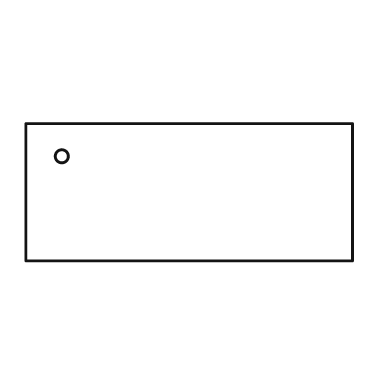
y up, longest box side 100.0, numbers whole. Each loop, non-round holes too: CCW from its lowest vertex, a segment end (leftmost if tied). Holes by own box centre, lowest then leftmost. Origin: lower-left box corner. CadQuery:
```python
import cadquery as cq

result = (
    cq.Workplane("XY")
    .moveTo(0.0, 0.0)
    .lineTo(100.0, 0.0)
    .lineTo(100.0, 42.0)
    .lineTo(0.0, 42.0)
    .close()
    .moveTo(11.0, 32.0)
    .circle(2.0)
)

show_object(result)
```